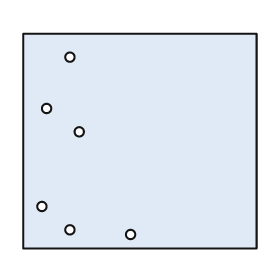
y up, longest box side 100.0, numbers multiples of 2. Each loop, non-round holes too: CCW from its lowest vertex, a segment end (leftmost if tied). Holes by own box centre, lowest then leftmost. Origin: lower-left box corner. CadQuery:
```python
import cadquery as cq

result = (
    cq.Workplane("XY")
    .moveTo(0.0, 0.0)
    .lineTo(100.0, 0.0)
    .lineTo(100.0, 92.0)
    .lineTo(0.0, 92.0)
    .close()
    .moveTo(46.0, 6.0)
    .circle(2.0)
    .moveTo(20.0, 8.0)
    .circle(2.0)
    .moveTo(8.0, 18.0)
    .circle(2.0)
    .moveTo(24.0, 50.0)
    .circle(2.0)
    .moveTo(10.0, 60.0)
    .circle(2.0)
    .moveTo(20.0, 82.0)
    .circle(2.0)
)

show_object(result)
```